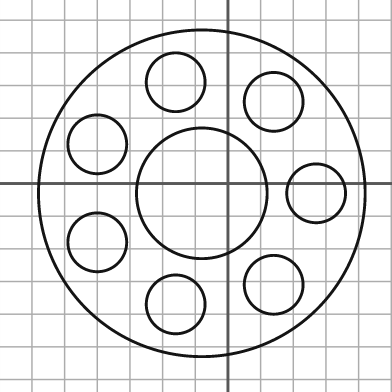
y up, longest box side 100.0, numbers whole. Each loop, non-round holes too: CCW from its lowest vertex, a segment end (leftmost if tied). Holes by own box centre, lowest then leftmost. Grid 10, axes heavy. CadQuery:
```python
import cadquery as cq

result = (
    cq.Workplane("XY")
    .moveTo(-8.0, -3.0)
    .circle(50.0)
    .moveTo(-16.0, -37.0)
    .circle(9.0)
    .moveTo(14.0, -31.0)
    .circle(9.0)
    .moveTo(-40.0, -18.0)
    .circle(9.0)
    .moveTo(-8.0, -3.0)
    .circle(20.0)
    .moveTo(27.0, -3.0)
    .circle(9.0)
    .moveTo(-40.0, 12.0)
    .circle(9.0)
    .moveTo(14.0, 25.0)
    .circle(9.0)
    .moveTo(-16.0, 31.0)
    .circle(9.0)
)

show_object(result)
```